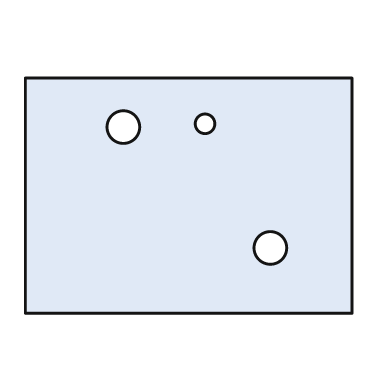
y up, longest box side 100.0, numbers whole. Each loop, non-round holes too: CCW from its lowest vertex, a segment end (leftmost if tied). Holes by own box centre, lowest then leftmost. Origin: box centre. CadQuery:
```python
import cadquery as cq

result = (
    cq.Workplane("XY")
    .moveTo(-50.0, -36.0)
    .lineTo(50.0, -36.0)
    .lineTo(50.0, 36.0)
    .lineTo(-50.0, 36.0)
    .close()
    .moveTo(25.0, -16.0)
    .circle(5.0)
    .moveTo(-20.0, 21.0)
    .circle(5.0)
    .moveTo(5.0, 22.0)
    .circle(3.0)
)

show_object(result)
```